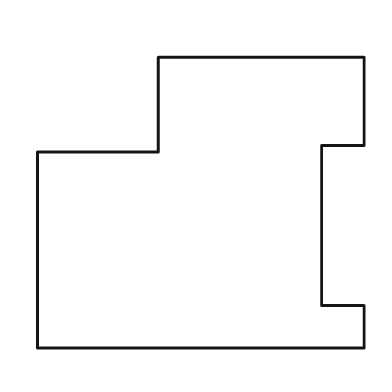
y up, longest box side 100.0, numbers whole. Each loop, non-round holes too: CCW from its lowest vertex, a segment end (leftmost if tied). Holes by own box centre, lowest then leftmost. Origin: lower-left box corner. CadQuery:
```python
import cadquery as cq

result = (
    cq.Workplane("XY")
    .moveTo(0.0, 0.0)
    .lineTo(100.0, 0.0)
    .lineTo(100.0, 13.0)
    .lineTo(87.0, 13.0)
    .lineTo(87.0, 62.0)
    .lineTo(100.0, 62.0)
    .lineTo(100.0, 89.0)
    .lineTo(37.0, 89.0)
    .lineTo(37.0, 60.0)
    .lineTo(0.0, 60.0)
    .close()
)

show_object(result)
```